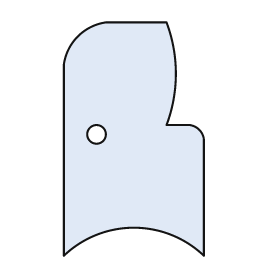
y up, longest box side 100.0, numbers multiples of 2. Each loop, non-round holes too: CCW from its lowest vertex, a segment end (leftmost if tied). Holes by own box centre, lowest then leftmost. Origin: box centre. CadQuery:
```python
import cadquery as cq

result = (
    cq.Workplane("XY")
    .moveTo(-30.0, -50.0)
    .threePointArc((0.0, -38.0), (30.0, -50.0))
    .lineTo(30.0, 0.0)
    .threePointArc((28.0, 4.0), (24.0, 6.0))
    .lineTo(14.0, 6.0)
    .threePointArc((18.0, 28.0), (14.0, 50.0))
    .lineTo(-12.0, 50.0)
    .threePointArc((-24.0, 44.0), (-30.0, 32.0))
    .close()
    .moveTo(-16.0, 2.0)
    .circle(4.0)
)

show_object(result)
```